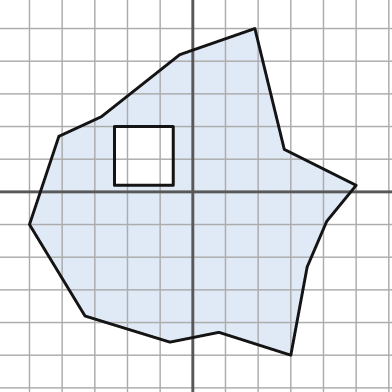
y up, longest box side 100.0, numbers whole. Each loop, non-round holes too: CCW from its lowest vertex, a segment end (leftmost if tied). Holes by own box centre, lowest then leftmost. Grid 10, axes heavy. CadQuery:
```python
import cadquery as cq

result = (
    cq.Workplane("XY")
    .moveTo(30.0, -50.0)
    .lineTo(35.0, -23.0)
    .lineTo(41.0, -9.0)
    .lineTo(50.0, 2.0)
    .lineTo(28.0, 13.0)
    .lineTo(19.0, 50.0)
    .lineTo(-4.0, 42.0)
    .lineTo(-28.0, 23.0)
    .lineTo(-41.0, 17.0)
    .lineTo(-50.0, -10.0)
    .lineTo(-33.0, -38.0)
    .lineTo(-7.0, -46.0)
    .lineTo(8.0, -43.0)
    .close()
    .moveTo(-24.0, 2.0)
    .lineTo(-6.0, 2.0)
    .lineTo(-6.0, 20.0)
    .lineTo(-24.0, 20.0)
    .close()
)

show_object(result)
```